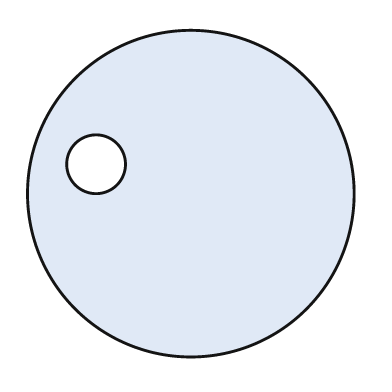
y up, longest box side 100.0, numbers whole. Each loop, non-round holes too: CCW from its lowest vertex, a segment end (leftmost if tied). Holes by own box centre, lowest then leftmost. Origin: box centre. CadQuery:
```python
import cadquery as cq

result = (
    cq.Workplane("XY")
    .moveTo(0.0, 0.0)
    .circle(50.0)
    .moveTo(-29.0, 9.0)
    .circle(9.0)
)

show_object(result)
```